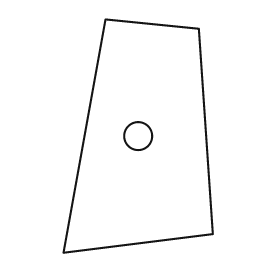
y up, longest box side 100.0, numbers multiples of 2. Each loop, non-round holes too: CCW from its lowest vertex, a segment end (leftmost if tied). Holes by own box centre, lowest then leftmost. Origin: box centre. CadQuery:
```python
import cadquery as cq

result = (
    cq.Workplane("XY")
    .moveTo(-32.0, -50.0)
    .lineTo(32.0, -42.0)
    .lineTo(26.0, 46.0)
    .lineTo(-14.0, 50.0)
    .close()
    .moveTo(0.0, 0.0)
    .circle(6.0)
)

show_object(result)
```